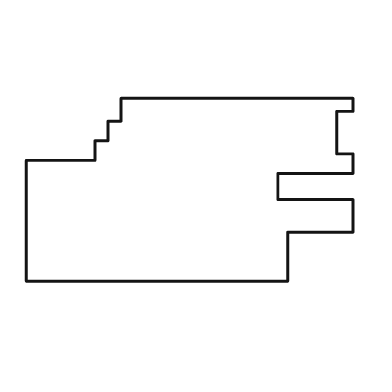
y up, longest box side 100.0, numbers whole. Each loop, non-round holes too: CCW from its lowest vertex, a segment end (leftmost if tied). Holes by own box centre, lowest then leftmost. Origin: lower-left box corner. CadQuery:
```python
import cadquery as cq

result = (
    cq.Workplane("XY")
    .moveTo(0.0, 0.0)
    .lineTo(80.0, 0.0)
    .lineTo(80.0, 15.0)
    .lineTo(100.0, 15.0)
    .lineTo(100.0, 25.0)
    .lineTo(77.0, 25.0)
    .lineTo(77.0, 33.0)
    .lineTo(100.0, 33.0)
    .lineTo(100.0, 39.0)
    .lineTo(95.0, 39.0)
    .lineTo(95.0, 52.0)
    .lineTo(100.0, 52.0)
    .lineTo(100.0, 56.0)
    .lineTo(29.0, 56.0)
    .lineTo(29.0, 49.0)
    .lineTo(25.0, 49.0)
    .lineTo(25.0, 43.0)
    .lineTo(21.0, 43.0)
    .lineTo(21.0, 37.0)
    .lineTo(0.0, 37.0)
    .close()
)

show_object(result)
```